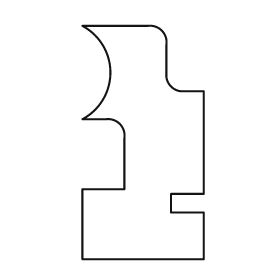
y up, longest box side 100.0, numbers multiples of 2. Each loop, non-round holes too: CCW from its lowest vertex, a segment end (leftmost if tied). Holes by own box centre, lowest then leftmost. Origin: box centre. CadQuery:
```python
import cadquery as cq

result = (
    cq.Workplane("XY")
    .moveTo(-26.0, -50.0)
    .lineTo(26.0, -50.0)
    .lineTo(26.0, -30.0)
    .lineTo(12.0, -30.0)
    .lineTo(12.0, -22.0)
    .lineTo(26.0, -22.0)
    .lineTo(26.0, 22.0)
    .lineTo(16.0, 22.0)
    .threePointArc((12.0, 24.0), (10.0, 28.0))
    .lineTo(10.0, 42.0)
    .threePointArc((8.0, 48.0), (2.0, 50.0))
    .lineTo(-26.0, 50.0)
    .threePointArc((-14.0, 30.0), (-26.0, 10.0))
    .lineTo(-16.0, 10.0)
    .threePointArc((-10.0, 8.0), (-8.0, 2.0))
    .lineTo(-8.0, -20.0)
    .lineTo(-26.0, -20.0)
    .close()
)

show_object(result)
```